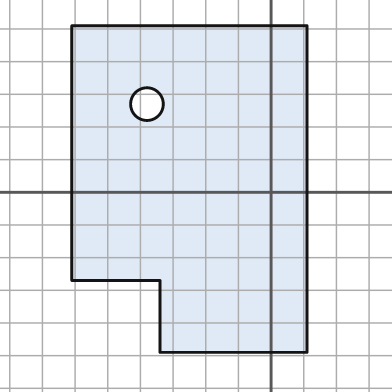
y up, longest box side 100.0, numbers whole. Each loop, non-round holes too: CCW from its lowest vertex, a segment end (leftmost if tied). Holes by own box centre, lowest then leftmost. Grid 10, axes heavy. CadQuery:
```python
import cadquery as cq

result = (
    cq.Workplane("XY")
    .moveTo(-34.0, -49.0)
    .lineTo(11.0, -49.0)
    .lineTo(11.0, 51.0)
    .lineTo(-61.0, 51.0)
    .lineTo(-61.0, -27.0)
    .lineTo(-34.0, -27.0)
    .close()
    .moveTo(-38.0, 27.0)
    .circle(5.0)
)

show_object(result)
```